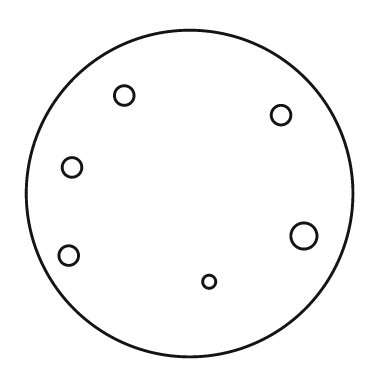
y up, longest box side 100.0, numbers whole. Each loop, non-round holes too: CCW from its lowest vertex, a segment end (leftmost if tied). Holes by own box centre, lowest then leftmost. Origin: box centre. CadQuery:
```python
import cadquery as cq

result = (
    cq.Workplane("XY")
    .moveTo(0.0, 0.0)
    .circle(50.0)
    .moveTo(6.0, -27.0)
    .circle(2.0)
    .moveTo(-37.0, -19.0)
    .circle(3.0)
    .moveTo(35.0, -13.0)
    .circle(4.0)
    .moveTo(-36.0, 8.0)
    .circle(3.0)
    .moveTo(28.0, 24.0)
    .circle(3.0)
    .moveTo(-20.0, 30.0)
    .circle(3.0)
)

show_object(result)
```